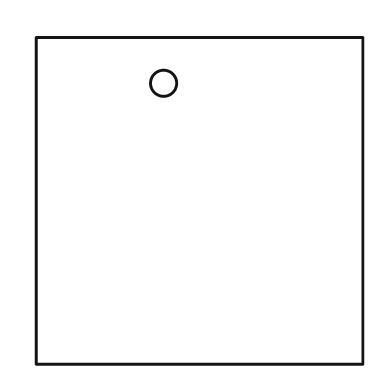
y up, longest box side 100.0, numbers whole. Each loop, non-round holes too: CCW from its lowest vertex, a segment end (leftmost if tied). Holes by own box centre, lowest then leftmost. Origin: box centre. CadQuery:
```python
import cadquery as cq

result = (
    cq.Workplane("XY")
    .moveTo(-50.0, -50.0)
    .lineTo(50.0, -50.0)
    .lineTo(50.0, 50.0)
    .lineTo(-50.0, 50.0)
    .close()
    .moveTo(-11.0, 36.0)
    .circle(4.0)
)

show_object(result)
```